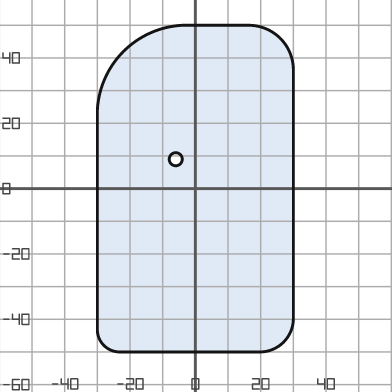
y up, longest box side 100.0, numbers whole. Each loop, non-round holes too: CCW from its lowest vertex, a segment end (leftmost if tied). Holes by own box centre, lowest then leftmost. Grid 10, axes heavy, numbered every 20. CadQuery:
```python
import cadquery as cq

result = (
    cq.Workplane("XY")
    .moveTo(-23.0, -50.0)
    .lineTo(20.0, -50.0)
    .threePointArc((27.0, -47.0), (30.0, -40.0))
    .lineTo(30.0, 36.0)
    .threePointArc((26.0, 46.0), (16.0, 50.0))
    .lineTo(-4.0, 50.0)
    .threePointArc((-22.0, 42.0), (-30.0, 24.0))
    .lineTo(-30.0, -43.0)
    .threePointArc((-28.0, -48.0), (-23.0, -50.0))
    .close()
    .moveTo(-6.0, 9.0)
    .circle(2.0)
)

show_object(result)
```